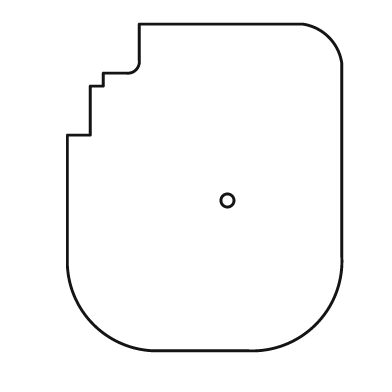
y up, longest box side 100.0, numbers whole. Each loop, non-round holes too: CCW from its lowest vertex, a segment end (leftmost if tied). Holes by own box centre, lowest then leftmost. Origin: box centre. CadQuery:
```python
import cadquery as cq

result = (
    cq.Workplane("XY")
    .moveTo(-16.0, -50.0)
    .lineTo(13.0, -50.0)
    .threePointArc((34.0, -42.0), (42.0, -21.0))
    .lineTo(42.0, 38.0)
    .threePointArc((38.0, 46.0), (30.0, 50.0))
    .lineTo(-20.0, 50.0)
    .lineTo(-20.0, 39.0)
    .threePointArc((-21.0, 36.0), (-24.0, 35.0))
    .lineTo(-31.0, 35.0)
    .lineTo(-31.0, 31.0)
    .lineTo(-35.0, 31.0)
    .lineTo(-35.0, 16.0)
    .lineTo(-42.0, 16.0)
    .lineTo(-42.0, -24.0)
    .threePointArc((-34.0, -42.0), (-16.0, -50.0))
    .close()
    .moveTo(7.0, -4.0)
    .circle(2.0)
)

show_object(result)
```